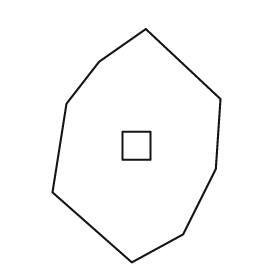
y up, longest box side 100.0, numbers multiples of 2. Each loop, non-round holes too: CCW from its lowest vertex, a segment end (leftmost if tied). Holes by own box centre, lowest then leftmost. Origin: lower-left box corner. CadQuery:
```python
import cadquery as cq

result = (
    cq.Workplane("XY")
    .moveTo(34.0, 0.0)
    .lineTo(56.0, 12.0)
    .lineTo(70.0, 40.0)
    .lineTo(72.0, 70.0)
    .lineTo(40.0, 100.0)
    .lineTo(20.0, 86.0)
    .lineTo(6.0, 68.0)
    .lineTo(0.0, 30.0)
    .close()
    .moveTo(30.0, 44.0)
    .lineTo(42.0, 44.0)
    .lineTo(42.0, 56.0)
    .lineTo(30.0, 56.0)
    .close()
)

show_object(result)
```